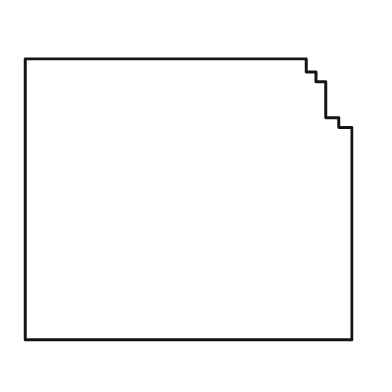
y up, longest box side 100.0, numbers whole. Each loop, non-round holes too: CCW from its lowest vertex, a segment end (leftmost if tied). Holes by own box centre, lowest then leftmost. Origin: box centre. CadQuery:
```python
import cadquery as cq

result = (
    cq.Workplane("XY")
    .moveTo(-50.0, -43.0)
    .lineTo(50.0, -43.0)
    .lineTo(50.0, 22.0)
    .lineTo(46.0, 22.0)
    .lineTo(46.0, 25.0)
    .lineTo(42.0, 25.0)
    .lineTo(42.0, 36.0)
    .lineTo(39.0, 36.0)
    .lineTo(39.0, 39.0)
    .lineTo(36.0, 39.0)
    .lineTo(36.0, 43.0)
    .lineTo(-50.0, 43.0)
    .close()
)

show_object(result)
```